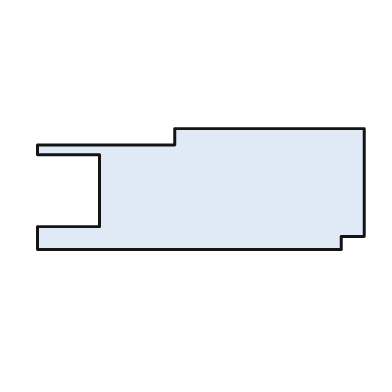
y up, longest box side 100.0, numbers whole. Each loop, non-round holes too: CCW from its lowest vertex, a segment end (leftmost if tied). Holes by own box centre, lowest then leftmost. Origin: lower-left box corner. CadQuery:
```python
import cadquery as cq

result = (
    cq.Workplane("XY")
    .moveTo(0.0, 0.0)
    .lineTo(93.0, 0.0)
    .lineTo(93.0, 4.0)
    .lineTo(100.0, 4.0)
    .lineTo(100.0, 37.0)
    .lineTo(42.0, 37.0)
    .lineTo(42.0, 32.0)
    .lineTo(0.0, 32.0)
    .lineTo(0.0, 29.0)
    .lineTo(19.0, 29.0)
    .lineTo(19.0, 7.0)
    .lineTo(0.0, 7.0)
    .close()
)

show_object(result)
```